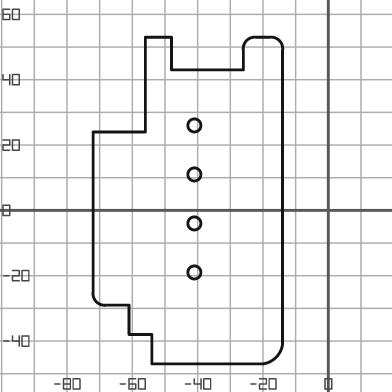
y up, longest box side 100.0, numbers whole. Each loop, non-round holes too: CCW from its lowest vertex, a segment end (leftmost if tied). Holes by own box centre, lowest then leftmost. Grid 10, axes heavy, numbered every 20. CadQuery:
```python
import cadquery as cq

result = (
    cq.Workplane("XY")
    .moveTo(-54.0, -47.0)
    .lineTo(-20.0, -47.0)
    .threePointArc((-16.0, -45.0), (-14.0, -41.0))
    .lineTo(-14.0, 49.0)
    .threePointArc((-15.0, 52.0), (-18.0, 53.0))
    .lineTo(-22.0, 53.0)
    .threePointArc((-25.0, 52.0), (-26.0, 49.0))
    .lineTo(-26.0, 43.0)
    .lineTo(-48.0, 43.0)
    .lineTo(-48.0, 53.0)
    .lineTo(-56.0, 53.0)
    .lineTo(-56.0, 24.0)
    .lineTo(-72.0, 24.0)
    .lineTo(-72.0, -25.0)
    .threePointArc((-71.0, -28.0), (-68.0, -29.0))
    .lineTo(-61.0, -29.0)
    .lineTo(-61.0, -38.0)
    .lineTo(-54.0, -38.0)
    .close()
    .moveTo(-41.0, -19.0)
    .circle(2.0)
    .moveTo(-41.0, -4.0)
    .circle(2.0)
    .moveTo(-41.0, 11.0)
    .circle(2.0)
    .moveTo(-41.0, 26.0)
    .circle(2.0)
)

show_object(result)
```